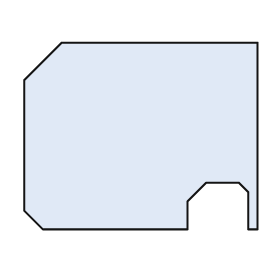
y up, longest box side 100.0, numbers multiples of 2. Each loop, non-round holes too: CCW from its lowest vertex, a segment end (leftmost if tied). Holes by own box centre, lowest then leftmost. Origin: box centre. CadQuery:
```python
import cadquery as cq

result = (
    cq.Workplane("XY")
    .moveTo(-42.0, -40.0)
    .lineTo(20.0, -40.0)
    .lineTo(20.0, -28.0)
    .lineTo(28.0, -20.0)
    .lineTo(42.0, -20.0)
    .lineTo(46.0, -24.0)
    .lineTo(46.0, -40.0)
    .lineTo(50.0, -40.0)
    .lineTo(50.0, 40.0)
    .lineTo(-34.0, 40.0)
    .lineTo(-50.0, 24.0)
    .lineTo(-50.0, -32.0)
    .close()
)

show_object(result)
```